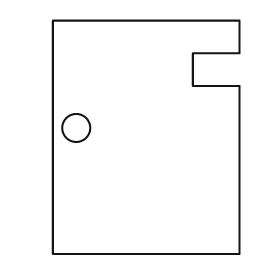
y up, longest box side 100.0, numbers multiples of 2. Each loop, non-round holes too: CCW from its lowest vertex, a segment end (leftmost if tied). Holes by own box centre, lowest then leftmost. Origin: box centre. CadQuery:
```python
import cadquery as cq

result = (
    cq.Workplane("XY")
    .moveTo(-40.0, -50.0)
    .lineTo(40.0, -50.0)
    .lineTo(40.0, 22.0)
    .lineTo(20.0, 22.0)
    .lineTo(20.0, 36.0)
    .lineTo(40.0, 36.0)
    .lineTo(40.0, 50.0)
    .lineTo(-40.0, 50.0)
    .close()
    .moveTo(-30.0, 4.0)
    .circle(6.0)
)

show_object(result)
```